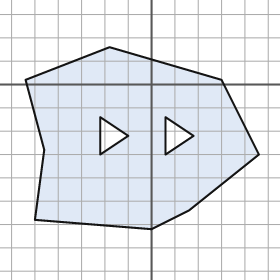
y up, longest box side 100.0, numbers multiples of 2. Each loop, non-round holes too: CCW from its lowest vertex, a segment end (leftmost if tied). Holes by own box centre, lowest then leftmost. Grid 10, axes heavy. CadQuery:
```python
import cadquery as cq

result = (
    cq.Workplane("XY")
    .moveTo(0.0, -62.0)
    .lineTo(16.0, -54.0)
    .lineTo(46.0, -30.0)
    .lineTo(30.0, 2.0)
    .lineTo(-18.0, 16.0)
    .lineTo(-54.0, 2.0)
    .lineTo(-46.0, -28.0)
    .lineTo(-50.0, -58.0)
    .close()
    .moveTo(-22.0, -30.0)
    .lineTo(-10.0, -22.0)
    .lineTo(-22.0, -14.0)
    .close()
    .moveTo(6.0, -30.0)
    .lineTo(18.0, -22.0)
    .lineTo(6.0, -14.0)
    .close()
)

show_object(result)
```